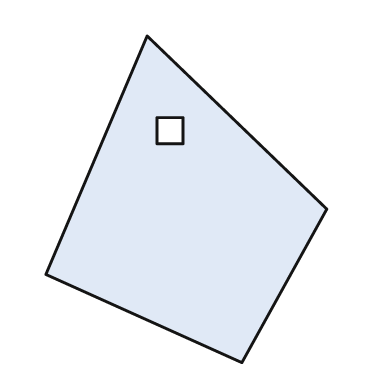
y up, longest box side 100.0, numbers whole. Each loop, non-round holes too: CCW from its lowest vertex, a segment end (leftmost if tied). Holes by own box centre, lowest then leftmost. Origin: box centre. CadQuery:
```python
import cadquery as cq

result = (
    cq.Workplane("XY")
    .moveTo(17.0, -50.0)
    .lineTo(43.0, -3.0)
    .lineTo(-12.0, 50.0)
    .lineTo(-43.0, -23.0)
    .close()
    .moveTo(-9.0, 17.0)
    .lineTo(-1.0, 17.0)
    .lineTo(-1.0, 25.0)
    .lineTo(-9.0, 25.0)
    .close()
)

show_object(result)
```